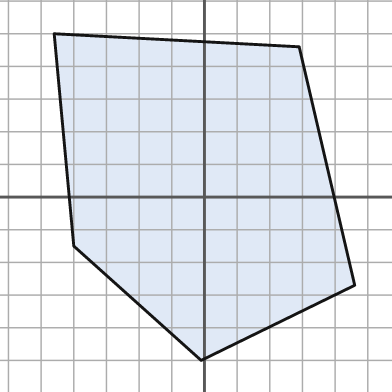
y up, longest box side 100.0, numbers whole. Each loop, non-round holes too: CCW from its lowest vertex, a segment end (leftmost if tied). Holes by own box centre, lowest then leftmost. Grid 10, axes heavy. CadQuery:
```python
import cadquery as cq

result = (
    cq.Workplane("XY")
    .moveTo(-1.0, -50.0)
    .lineTo(46.0, -27.0)
    .lineTo(29.0, 46.0)
    .lineTo(-46.0, 50.0)
    .lineTo(-40.0, -15.0)
    .close()
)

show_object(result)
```